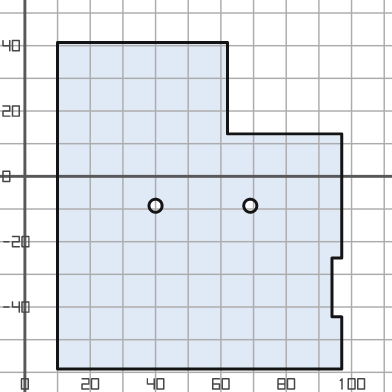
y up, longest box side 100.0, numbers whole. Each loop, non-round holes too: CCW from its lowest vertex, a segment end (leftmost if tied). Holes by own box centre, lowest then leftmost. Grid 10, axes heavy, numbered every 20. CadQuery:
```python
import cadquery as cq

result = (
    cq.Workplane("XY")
    .moveTo(10.0, -59.0)
    .lineTo(97.0, -59.0)
    .lineTo(97.0, -43.0)
    .lineTo(94.0, -43.0)
    .lineTo(94.0, -25.0)
    .lineTo(97.0, -25.0)
    .lineTo(97.0, 13.0)
    .lineTo(62.0, 13.0)
    .lineTo(62.0, 41.0)
    .lineTo(10.0, 41.0)
    .close()
    .moveTo(40.0, -9.0)
    .circle(2.0)
    .moveTo(69.0, -9.0)
    .circle(2.0)
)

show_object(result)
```